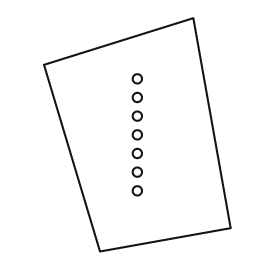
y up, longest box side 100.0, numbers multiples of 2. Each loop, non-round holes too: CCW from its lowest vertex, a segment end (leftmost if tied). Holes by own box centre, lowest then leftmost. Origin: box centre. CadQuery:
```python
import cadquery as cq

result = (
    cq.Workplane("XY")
    .moveTo(-16.0, -50.0)
    .lineTo(40.0, -40.0)
    .lineTo(24.0, 50.0)
    .lineTo(-40.0, 30.0)
    .close()
    .moveTo(0.0, -24.0)
    .circle(2.0)
    .moveTo(0.0, -16.0)
    .circle(2.0)
    .moveTo(0.0, -8.0)
    .circle(2.0)
    .moveTo(0.0, 0.0)
    .circle(2.0)
    .moveTo(0.0, 8.0)
    .circle(2.0)
    .moveTo(0.0, 16.0)
    .circle(2.0)
    .moveTo(0.0, 24.0)
    .circle(2.0)
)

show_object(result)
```